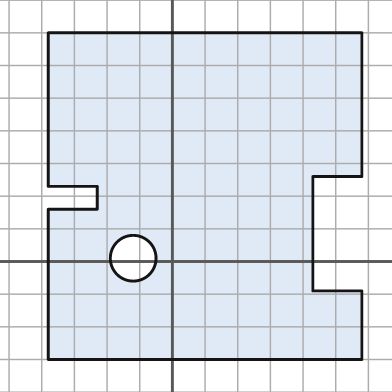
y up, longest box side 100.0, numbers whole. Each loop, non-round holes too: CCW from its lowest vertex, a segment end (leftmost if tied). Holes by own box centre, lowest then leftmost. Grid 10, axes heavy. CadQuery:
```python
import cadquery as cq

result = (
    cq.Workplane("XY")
    .moveTo(-38.0, -30.0)
    .lineTo(58.0, -30.0)
    .lineTo(58.0, -9.0)
    .lineTo(43.0, -9.0)
    .lineTo(43.0, 26.0)
    .lineTo(58.0, 26.0)
    .lineTo(58.0, 70.0)
    .lineTo(-38.0, 70.0)
    .lineTo(-38.0, 23.0)
    .lineTo(-23.0, 23.0)
    .lineTo(-23.0, 16.0)
    .lineTo(-38.0, 16.0)
    .close()
    .moveTo(-12.0, 1.0)
    .circle(7.0)
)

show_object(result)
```